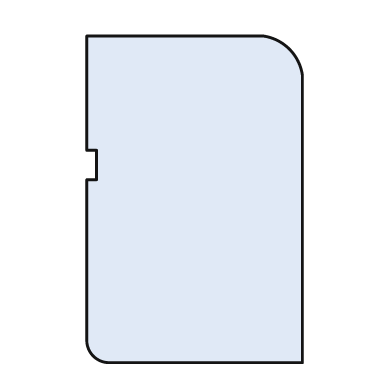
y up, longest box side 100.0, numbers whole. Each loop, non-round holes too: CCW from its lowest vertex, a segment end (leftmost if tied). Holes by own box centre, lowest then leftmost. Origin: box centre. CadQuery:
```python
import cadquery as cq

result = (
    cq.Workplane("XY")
    .moveTo(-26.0, -50.0)
    .lineTo(33.0, -50.0)
    .lineTo(33.0, 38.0)
    .threePointArc((29.0, 46.0), (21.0, 50.0))
    .lineTo(-33.0, 50.0)
    .lineTo(-33.0, 15.0)
    .lineTo(-30.0, 15.0)
    .lineTo(-30.0, 6.0)
    .lineTo(-33.0, 6.0)
    .lineTo(-33.0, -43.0)
    .threePointArc((-31.0, -48.0), (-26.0, -50.0))
    .close()
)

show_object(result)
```